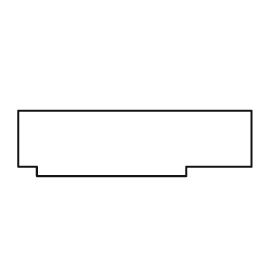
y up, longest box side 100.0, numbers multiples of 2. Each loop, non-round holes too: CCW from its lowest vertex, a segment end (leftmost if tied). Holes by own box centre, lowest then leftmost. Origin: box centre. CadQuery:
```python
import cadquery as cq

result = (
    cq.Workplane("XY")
    .moveTo(-42.0, -14.0)
    .lineTo(22.0, -14.0)
    .lineTo(22.0, -10.0)
    .lineTo(50.0, -10.0)
    .lineTo(50.0, 14.0)
    .lineTo(-50.0, 14.0)
    .lineTo(-50.0, -10.0)
    .lineTo(-42.0, -10.0)
    .close()
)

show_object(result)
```